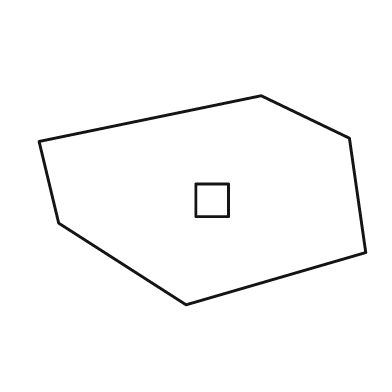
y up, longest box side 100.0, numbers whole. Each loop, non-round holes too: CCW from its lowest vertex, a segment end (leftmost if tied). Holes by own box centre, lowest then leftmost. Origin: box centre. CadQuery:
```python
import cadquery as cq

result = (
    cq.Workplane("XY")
    .moveTo(-5.0, -32.0)
    .lineTo(50.0, -16.0)
    .lineTo(45.0, 19.0)
    .lineTo(18.0, 32.0)
    .lineTo(-50.0, 18.0)
    .lineTo(-44.0, -7.0)
    .close()
    .moveTo(-2.0, -5.0)
    .lineTo(8.0, -5.0)
    .lineTo(8.0, 5.0)
    .lineTo(-2.0, 5.0)
    .close()
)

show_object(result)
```